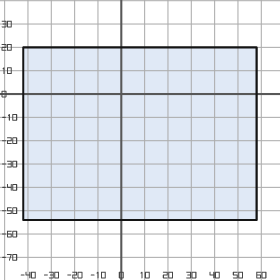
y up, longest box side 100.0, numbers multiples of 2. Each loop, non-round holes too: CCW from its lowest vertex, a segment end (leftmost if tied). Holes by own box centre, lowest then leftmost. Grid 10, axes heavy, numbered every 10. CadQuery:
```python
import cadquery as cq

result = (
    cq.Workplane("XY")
    .moveTo(-42.0, -54.0)
    .lineTo(58.0, -54.0)
    .lineTo(58.0, 20.0)
    .lineTo(-42.0, 20.0)
    .close()
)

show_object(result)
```